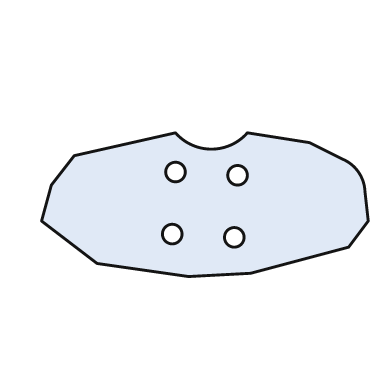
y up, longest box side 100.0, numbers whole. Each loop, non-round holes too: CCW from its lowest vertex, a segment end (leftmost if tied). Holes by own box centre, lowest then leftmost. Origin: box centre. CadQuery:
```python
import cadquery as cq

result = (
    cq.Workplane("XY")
    .moveTo(-5.0, -22.0)
    .lineTo(14.0, -21.0)
    .lineTo(44.0, -13.0)
    .lineTo(50.0, -5.0)
    .lineTo(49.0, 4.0)
    .threePointArc((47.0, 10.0), (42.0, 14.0))
    .lineTo(32.0, 19.0)
    .lineTo(13.0, 22.0)
    .threePointArc((2.0, 17.0), (-9.0, 22.0))
    .lineTo(-40.0, 15.0)
    .lineTo(-47.0, 6.0)
    .lineTo(-50.0, -5.0)
    .lineTo(-33.0, -18.0)
    .close()
    .moveTo(9.0, -10.0)
    .circle(3.0)
    .moveTo(-10.0, -9.0)
    .circle(3.0)
    .moveTo(10.0, 9.0)
    .circle(3.0)
    .moveTo(-9.0, 10.0)
    .circle(3.0)
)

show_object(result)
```